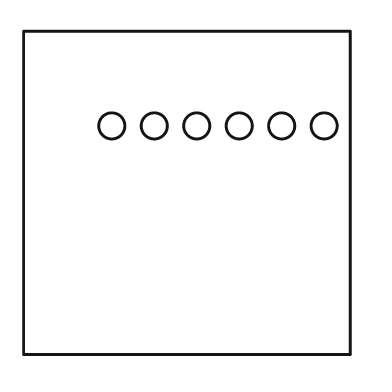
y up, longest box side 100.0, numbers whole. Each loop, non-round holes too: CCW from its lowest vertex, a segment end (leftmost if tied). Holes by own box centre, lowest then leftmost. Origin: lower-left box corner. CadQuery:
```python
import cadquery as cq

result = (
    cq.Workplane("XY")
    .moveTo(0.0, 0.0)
    .lineTo(100.0, 0.0)
    .lineTo(100.0, 99.0)
    .lineTo(0.0, 99.0)
    .close()
    .moveTo(27.0, 70.0)
    .circle(4.0)
    .moveTo(40.0, 70.0)
    .circle(4.0)
    .moveTo(53.0, 70.0)
    .circle(4.0)
    .moveTo(66.0, 70.0)
    .circle(4.0)
    .moveTo(79.0, 70.0)
    .circle(4.0)
    .moveTo(92.0, 70.0)
    .circle(4.0)
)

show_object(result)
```